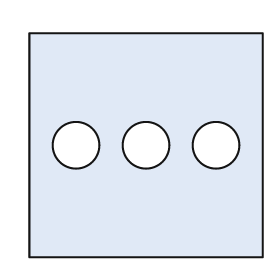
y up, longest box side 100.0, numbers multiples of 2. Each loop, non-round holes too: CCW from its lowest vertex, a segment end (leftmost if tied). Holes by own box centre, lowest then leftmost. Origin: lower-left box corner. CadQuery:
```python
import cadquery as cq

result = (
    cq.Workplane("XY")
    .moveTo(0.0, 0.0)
    .lineTo(100.0, 0.0)
    .lineTo(100.0, 96.0)
    .lineTo(0.0, 96.0)
    .close()
    .moveTo(20.0, 48.0)
    .circle(10.0)
    .moveTo(50.0, 48.0)
    .circle(10.0)
    .moveTo(80.0, 48.0)
    .circle(10.0)
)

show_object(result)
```